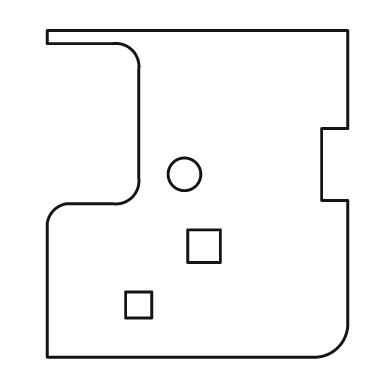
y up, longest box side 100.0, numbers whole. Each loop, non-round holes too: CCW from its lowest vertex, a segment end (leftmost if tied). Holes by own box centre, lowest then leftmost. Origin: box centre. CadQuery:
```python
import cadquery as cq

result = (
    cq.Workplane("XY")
    .moveTo(-46.0, -50.0)
    .lineTo(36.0, -50.0)
    .threePointArc((43.0, -47.0), (46.0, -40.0))
    .lineTo(46.0, -2.0)
    .lineTo(38.0, -2.0)
    .lineTo(38.0, 20.0)
    .lineTo(46.0, 20.0)
    .lineTo(46.0, 50.0)
    .lineTo(-46.0, 50.0)
    .lineTo(-46.0, 46.0)
    .lineTo(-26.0, 46.0)
    .threePointArc((-20.0, 44.0), (-18.0, 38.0))
    .lineTo(-18.0, 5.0)
    .threePointArc((-20.0, -1.0), (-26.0, -3.0))
    .lineTo(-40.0, -3.0)
    .threePointArc((-44.0, -5.0), (-46.0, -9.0))
    .close()
    .moveTo(-22.0, -38.0)
    .lineTo(-14.0, -38.0)
    .lineTo(-14.0, -30.0)
    .lineTo(-22.0, -30.0)
    .close()
    .moveTo(-3.0, -21.0)
    .lineTo(7.0, -21.0)
    .lineTo(7.0, -11.0)
    .lineTo(-3.0, -11.0)
    .close()
    .moveTo(-4.0, 6.0)
    .circle(5.0)
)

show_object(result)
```